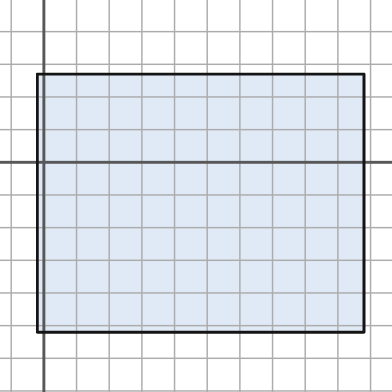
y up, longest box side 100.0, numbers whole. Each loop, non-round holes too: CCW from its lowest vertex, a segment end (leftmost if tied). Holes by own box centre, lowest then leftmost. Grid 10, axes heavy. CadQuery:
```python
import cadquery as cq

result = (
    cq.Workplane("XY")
    .moveTo(-2.0, -52.0)
    .lineTo(98.0, -52.0)
    .lineTo(98.0, 27.0)
    .lineTo(-2.0, 27.0)
    .close()
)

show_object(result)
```